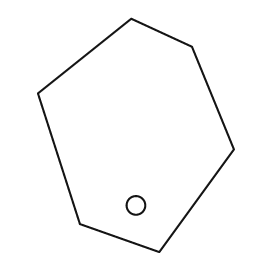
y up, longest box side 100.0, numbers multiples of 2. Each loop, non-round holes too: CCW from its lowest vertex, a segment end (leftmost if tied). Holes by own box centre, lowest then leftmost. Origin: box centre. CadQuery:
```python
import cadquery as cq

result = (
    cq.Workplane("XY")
    .moveTo(10.0, -50.0)
    .lineTo(42.0, -6.0)
    .lineTo(24.0, 38.0)
    .lineTo(-2.0, 50.0)
    .lineTo(-42.0, 18.0)
    .lineTo(-24.0, -38.0)
    .close()
    .moveTo(0.0, -30.0)
    .circle(4.0)
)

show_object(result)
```